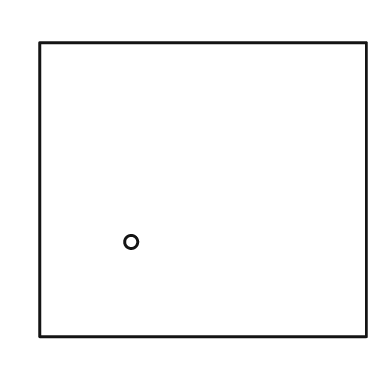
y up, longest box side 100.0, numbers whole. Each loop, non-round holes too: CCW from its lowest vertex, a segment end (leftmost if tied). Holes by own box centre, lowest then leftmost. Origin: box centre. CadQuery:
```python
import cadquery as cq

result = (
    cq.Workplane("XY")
    .moveTo(-50.0, -45.0)
    .lineTo(50.0, -45.0)
    .lineTo(50.0, 45.0)
    .lineTo(-50.0, 45.0)
    .close()
    .moveTo(-22.0, -16.0)
    .circle(2.0)
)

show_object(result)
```